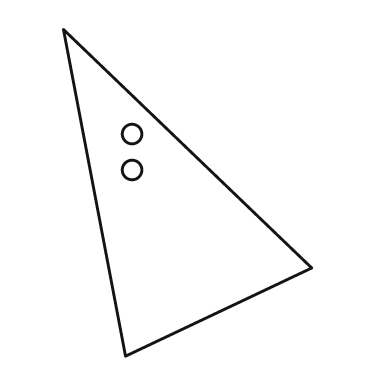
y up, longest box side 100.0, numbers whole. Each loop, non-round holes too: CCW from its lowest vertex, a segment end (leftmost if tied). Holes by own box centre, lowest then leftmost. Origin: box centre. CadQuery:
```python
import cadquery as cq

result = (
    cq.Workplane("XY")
    .moveTo(-19.0, -50.0)
    .lineTo(38.0, -23.0)
    .lineTo(-38.0, 50.0)
    .close()
    .moveTo(-17.0, 7.0)
    .circle(3.0)
    .moveTo(-17.0, 18.0)
    .circle(3.0)
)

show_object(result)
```